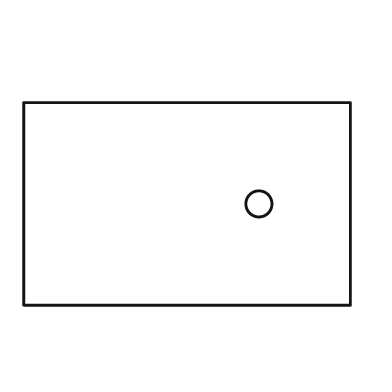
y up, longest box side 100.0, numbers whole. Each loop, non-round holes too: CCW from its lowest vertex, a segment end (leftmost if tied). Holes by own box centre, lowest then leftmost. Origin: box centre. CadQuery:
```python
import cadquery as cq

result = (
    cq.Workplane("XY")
    .moveTo(-50.0, -31.0)
    .lineTo(50.0, -31.0)
    .lineTo(50.0, 31.0)
    .lineTo(-50.0, 31.0)
    .close()
    .moveTo(22.0, 0.0)
    .circle(4.0)
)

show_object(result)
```